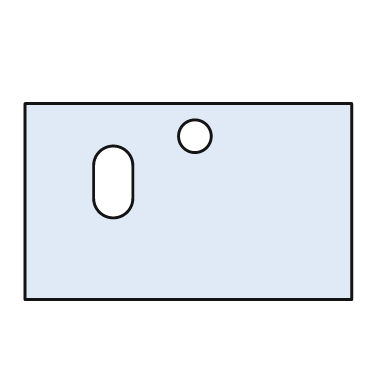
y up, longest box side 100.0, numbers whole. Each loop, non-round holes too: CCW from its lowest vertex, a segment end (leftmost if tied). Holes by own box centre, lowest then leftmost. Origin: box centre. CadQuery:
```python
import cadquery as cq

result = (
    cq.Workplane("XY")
    .moveTo(-50.0, -30.0)
    .lineTo(50.0, -30.0)
    .lineTo(50.0, 30.0)
    .lineTo(-50.0, 30.0)
    .close()
    .moveTo(-29.0, 1.0)
    .threePointArc((-23.0, -5.0), (-17.0, 1.0))
    .lineTo(-17.0, 11.0)
    .threePointArc((-23.0, 17.0), (-29.0, 11.0))
    .close()
    .moveTo(2.0, 20.0)
    .circle(5.0)
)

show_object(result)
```